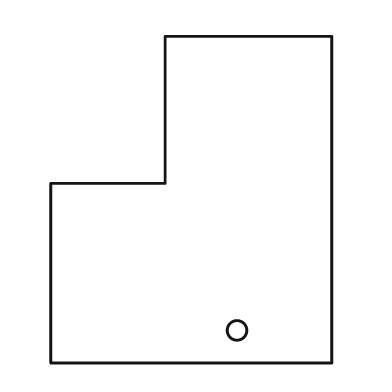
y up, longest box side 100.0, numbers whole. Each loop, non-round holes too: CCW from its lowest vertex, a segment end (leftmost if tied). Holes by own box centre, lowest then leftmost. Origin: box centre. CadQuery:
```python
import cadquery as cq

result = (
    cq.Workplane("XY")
    .moveTo(-43.0, -50.0)
    .lineTo(43.0, -50.0)
    .lineTo(43.0, 50.0)
    .lineTo(-8.0, 50.0)
    .lineTo(-8.0, 5.0)
    .lineTo(-43.0, 5.0)
    .close()
    .moveTo(14.0, -40.0)
    .circle(3.0)
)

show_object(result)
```